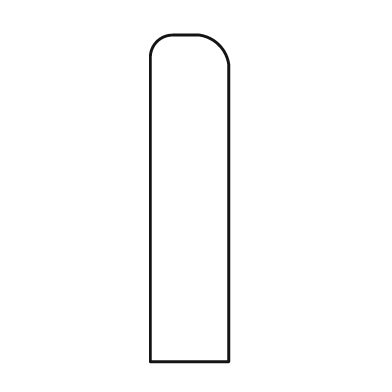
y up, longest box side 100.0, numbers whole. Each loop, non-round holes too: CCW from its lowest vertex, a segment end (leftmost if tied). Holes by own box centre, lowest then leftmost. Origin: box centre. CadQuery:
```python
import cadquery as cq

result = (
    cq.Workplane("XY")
    .moveTo(-12.0, -50.0)
    .lineTo(12.0, -50.0)
    .lineTo(12.0, 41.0)
    .threePointArc((9.0, 47.0), (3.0, 50.0))
    .lineTo(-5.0, 50.0)
    .threePointArc((-10.0, 48.0), (-12.0, 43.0))
    .close()
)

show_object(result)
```